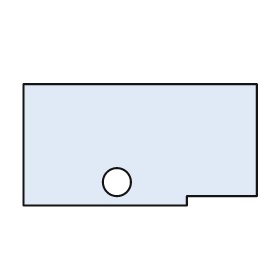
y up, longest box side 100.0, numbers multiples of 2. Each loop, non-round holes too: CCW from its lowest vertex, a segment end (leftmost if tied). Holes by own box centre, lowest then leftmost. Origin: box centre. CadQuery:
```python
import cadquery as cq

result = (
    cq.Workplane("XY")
    .moveTo(-50.0, -26.0)
    .lineTo(20.0, -26.0)
    .lineTo(20.0, -22.0)
    .lineTo(50.0, -22.0)
    .lineTo(50.0, 26.0)
    .lineTo(-50.0, 26.0)
    .close()
    .moveTo(-10.0, -16.0)
    .circle(6.0)
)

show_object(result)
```